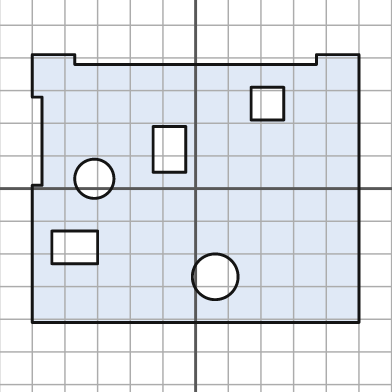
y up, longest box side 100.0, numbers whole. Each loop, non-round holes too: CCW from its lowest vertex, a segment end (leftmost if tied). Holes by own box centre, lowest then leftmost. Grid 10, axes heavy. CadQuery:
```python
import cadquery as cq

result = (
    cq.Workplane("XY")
    .moveTo(-50.0, -41.0)
    .lineTo(50.0, -41.0)
    .lineTo(50.0, 41.0)
    .lineTo(37.0, 41.0)
    .lineTo(37.0, 38.0)
    .lineTo(-37.0, 38.0)
    .lineTo(-37.0, 41.0)
    .lineTo(-50.0, 41.0)
    .lineTo(-50.0, 28.0)
    .lineTo(-47.0, 28.0)
    .lineTo(-47.0, 1.0)
    .lineTo(-50.0, 1.0)
    .close()
    .moveTo(6.0, -27.0)
    .circle(7.0)
    .moveTo(-44.0, -23.0)
    .lineTo(-30.0, -23.0)
    .lineTo(-30.0, -13.0)
    .lineTo(-44.0, -13.0)
    .close()
    .moveTo(-31.0, 3.0)
    .circle(6.0)
    .moveTo(-13.0, 5.0)
    .lineTo(-3.0, 5.0)
    .lineTo(-3.0, 19.0)
    .lineTo(-13.0, 19.0)
    .close()
    .moveTo(17.0, 21.0)
    .lineTo(27.0, 21.0)
    .lineTo(27.0, 31.0)
    .lineTo(17.0, 31.0)
    .close()
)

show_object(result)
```